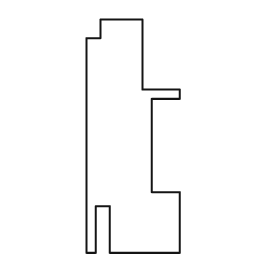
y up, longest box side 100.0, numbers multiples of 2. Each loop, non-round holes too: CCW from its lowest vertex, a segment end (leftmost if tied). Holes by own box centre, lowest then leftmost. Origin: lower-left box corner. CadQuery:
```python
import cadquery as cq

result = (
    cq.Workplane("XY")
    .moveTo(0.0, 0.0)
    .lineTo(4.0, 0.0)
    .lineTo(4.0, 20.0)
    .lineTo(10.0, 20.0)
    .lineTo(10.0, 0.0)
    .lineTo(40.0, 0.0)
    .lineTo(40.0, 26.0)
    .lineTo(28.0, 26.0)
    .lineTo(28.0, 66.0)
    .lineTo(40.0, 66.0)
    .lineTo(40.0, 70.0)
    .lineTo(24.0, 70.0)
    .lineTo(24.0, 100.0)
    .lineTo(6.0, 100.0)
    .lineTo(6.0, 92.0)
    .lineTo(0.0, 92.0)
    .close()
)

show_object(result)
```